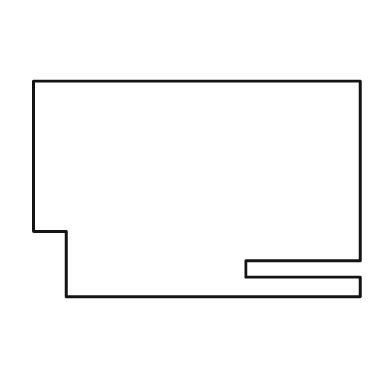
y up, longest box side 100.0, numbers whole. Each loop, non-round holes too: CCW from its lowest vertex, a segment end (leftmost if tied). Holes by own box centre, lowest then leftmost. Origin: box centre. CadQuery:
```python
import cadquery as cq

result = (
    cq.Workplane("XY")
    .moveTo(-40.0, -33.0)
    .lineTo(50.0, -33.0)
    .lineTo(50.0, -27.0)
    .lineTo(15.0, -27.0)
    .lineTo(15.0, -22.0)
    .lineTo(50.0, -22.0)
    .lineTo(50.0, 33.0)
    .lineTo(-50.0, 33.0)
    .lineTo(-50.0, -13.0)
    .lineTo(-40.0, -13.0)
    .close()
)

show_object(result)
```